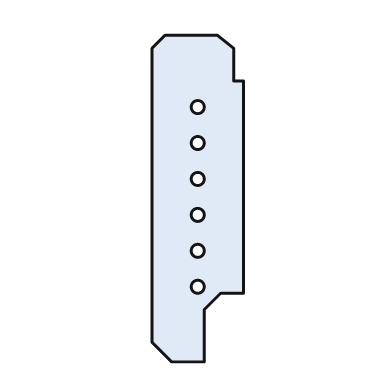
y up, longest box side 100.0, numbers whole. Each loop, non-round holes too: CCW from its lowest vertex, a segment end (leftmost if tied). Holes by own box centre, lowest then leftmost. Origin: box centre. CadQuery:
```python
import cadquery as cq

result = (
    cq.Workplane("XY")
    .moveTo(-8.0, -50.0)
    .lineTo(2.0, -50.0)
    .lineTo(2.0, -34.0)
    .lineTo(7.0, -29.0)
    .lineTo(14.0, -29.0)
    .lineTo(14.0, 36.0)
    .lineTo(11.0, 36.0)
    .lineTo(11.0, 46.0)
    .lineTo(6.0, 50.0)
    .lineTo(-10.0, 50.0)
    .lineTo(-14.0, 46.0)
    .lineTo(-14.0, -44.0)
    .close()
    .moveTo(0.0, -27.0)
    .circle(2.0)
    .moveTo(0.0, -16.0)
    .circle(2.0)
    .moveTo(0.0, -5.0)
    .circle(2.0)
    .moveTo(0.0, 6.0)
    .circle(2.0)
    .moveTo(0.0, 17.0)
    .circle(2.0)
    .moveTo(0.0, 28.0)
    .circle(2.0)
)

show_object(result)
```